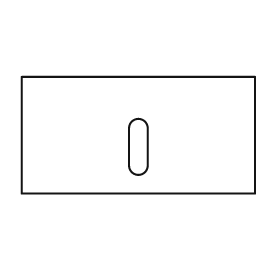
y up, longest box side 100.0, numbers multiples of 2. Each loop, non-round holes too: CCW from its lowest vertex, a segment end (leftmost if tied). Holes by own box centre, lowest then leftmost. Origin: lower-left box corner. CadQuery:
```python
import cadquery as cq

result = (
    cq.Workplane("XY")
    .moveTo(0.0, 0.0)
    .lineTo(100.0, 0.0)
    .lineTo(100.0, 50.0)
    .lineTo(0.0, 50.0)
    .close()
    .moveTo(46.0, 12.0)
    .threePointArc((50.0, 8.0), (54.0, 12.0))
    .lineTo(54.0, 28.0)
    .threePointArc((50.0, 32.0), (46.0, 28.0))
    .close()
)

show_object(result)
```